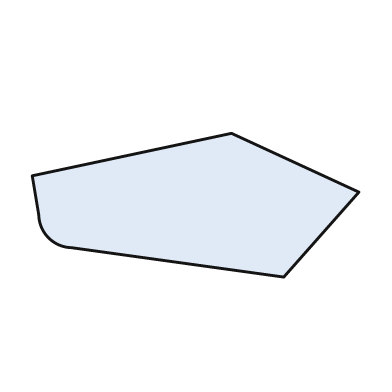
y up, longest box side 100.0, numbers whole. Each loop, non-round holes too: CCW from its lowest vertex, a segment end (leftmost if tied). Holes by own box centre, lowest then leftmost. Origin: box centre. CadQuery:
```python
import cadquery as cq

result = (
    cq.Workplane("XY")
    .moveTo(27.0, -22.0)
    .lineTo(50.0, 4.0)
    .lineTo(11.0, 22.0)
    .lineTo(-50.0, 9.0)
    .lineTo(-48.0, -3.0)
    .threePointArc((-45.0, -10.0), (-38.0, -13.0))
    .close()
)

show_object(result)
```